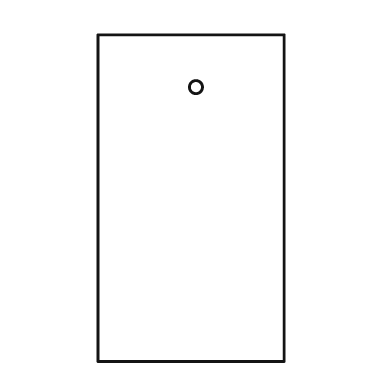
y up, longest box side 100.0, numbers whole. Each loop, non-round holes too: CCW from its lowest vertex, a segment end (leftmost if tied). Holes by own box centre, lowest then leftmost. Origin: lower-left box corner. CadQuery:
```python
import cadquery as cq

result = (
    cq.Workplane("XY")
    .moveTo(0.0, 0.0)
    .lineTo(57.0, 0.0)
    .lineTo(57.0, 100.0)
    .lineTo(0.0, 100.0)
    .close()
    .moveTo(30.0, 84.0)
    .circle(2.0)
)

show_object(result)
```